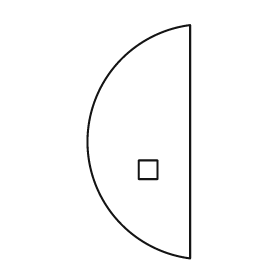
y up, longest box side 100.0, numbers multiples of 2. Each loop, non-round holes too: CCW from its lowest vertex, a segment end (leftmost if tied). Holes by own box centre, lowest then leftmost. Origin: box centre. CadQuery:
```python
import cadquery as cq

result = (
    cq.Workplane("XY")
    .moveTo(22.0, -50.0)
    .lineTo(22.0, 50.0)
    .threePointArc((-22.0, 0.0), (22.0, -50.0))
    .close()
    .moveTo(0.0, -16.0)
    .lineTo(8.0, -16.0)
    .lineTo(8.0, -8.0)
    .lineTo(0.0, -8.0)
    .close()
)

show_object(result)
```